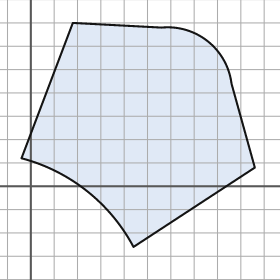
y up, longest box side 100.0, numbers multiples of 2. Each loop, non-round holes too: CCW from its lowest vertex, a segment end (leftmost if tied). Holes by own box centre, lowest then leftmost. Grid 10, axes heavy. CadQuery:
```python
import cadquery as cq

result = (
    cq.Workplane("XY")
    .moveTo(44.0, -26.0)
    .lineTo(96.0, 8.0)
    .lineTo(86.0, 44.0)
    .threePointArc((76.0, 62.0), (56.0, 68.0))
    .lineTo(18.0, 70.0)
    .lineTo(-4.0, 12.0)
    .threePointArc((24.0, -2.0), (44.0, -26.0))
    .close()
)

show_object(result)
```